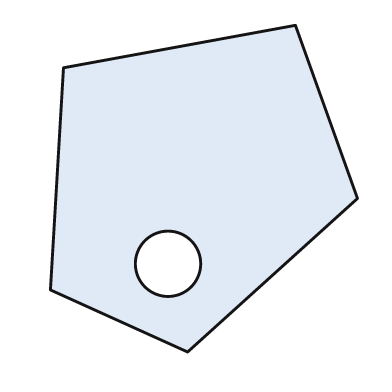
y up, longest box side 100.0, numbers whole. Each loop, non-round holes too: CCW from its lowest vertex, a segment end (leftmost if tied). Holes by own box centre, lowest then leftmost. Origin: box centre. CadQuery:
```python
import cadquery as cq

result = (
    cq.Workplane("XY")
    .moveTo(-5.0, -50.0)
    .lineTo(47.0, -3.0)
    .lineTo(28.0, 50.0)
    .lineTo(-43.0, 37.0)
    .lineTo(-47.0, -31.0)
    .close()
    .moveTo(-11.0, -23.0)
    .circle(10.0)
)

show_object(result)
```